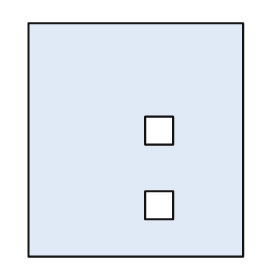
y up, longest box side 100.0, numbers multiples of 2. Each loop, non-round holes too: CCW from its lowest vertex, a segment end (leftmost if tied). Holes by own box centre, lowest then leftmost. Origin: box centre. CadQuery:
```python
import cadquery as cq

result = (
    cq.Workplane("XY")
    .moveTo(-46.0, -50.0)
    .lineTo(46.0, -50.0)
    .lineTo(46.0, 50.0)
    .lineTo(-46.0, 50.0)
    .close()
    .moveTo(4.0, -34.0)
    .lineTo(16.0, -34.0)
    .lineTo(16.0, -22.0)
    .lineTo(4.0, -22.0)
    .close()
    .moveTo(4.0, -2.0)
    .lineTo(16.0, -2.0)
    .lineTo(16.0, 10.0)
    .lineTo(4.0, 10.0)
    .close()
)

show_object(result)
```